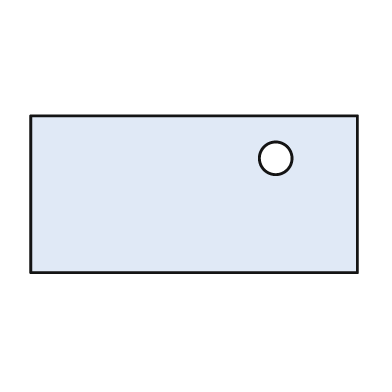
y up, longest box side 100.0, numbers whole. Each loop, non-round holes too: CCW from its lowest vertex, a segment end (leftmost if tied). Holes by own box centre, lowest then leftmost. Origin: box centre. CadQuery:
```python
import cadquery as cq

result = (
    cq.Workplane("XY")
    .moveTo(-50.0, -24.0)
    .lineTo(50.0, -24.0)
    .lineTo(50.0, 24.0)
    .lineTo(-50.0, 24.0)
    .close()
    .moveTo(25.0, 11.0)
    .circle(5.0)
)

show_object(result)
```